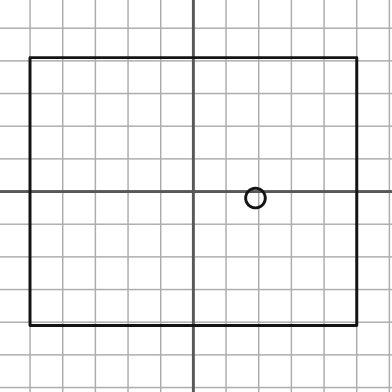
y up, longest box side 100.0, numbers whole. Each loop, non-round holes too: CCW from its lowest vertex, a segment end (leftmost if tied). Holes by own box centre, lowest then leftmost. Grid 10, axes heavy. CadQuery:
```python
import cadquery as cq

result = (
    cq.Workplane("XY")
    .moveTo(-50.0, -41.0)
    .lineTo(50.0, -41.0)
    .lineTo(50.0, 41.0)
    .lineTo(-50.0, 41.0)
    .close()
    .moveTo(19.0, -2.0)
    .circle(3.0)
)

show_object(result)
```